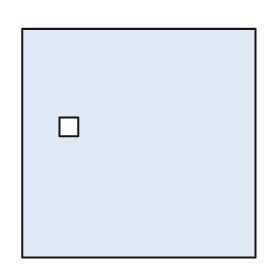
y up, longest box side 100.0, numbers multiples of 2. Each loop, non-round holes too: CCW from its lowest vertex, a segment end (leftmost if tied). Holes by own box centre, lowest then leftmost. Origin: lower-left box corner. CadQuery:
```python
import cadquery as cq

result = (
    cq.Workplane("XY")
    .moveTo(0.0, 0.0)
    .lineTo(100.0, 0.0)
    .lineTo(100.0, 98.0)
    .lineTo(0.0, 98.0)
    .close()
    .moveTo(16.0, 52.0)
    .lineTo(24.0, 52.0)
    .lineTo(24.0, 60.0)
    .lineTo(16.0, 60.0)
    .close()
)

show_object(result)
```